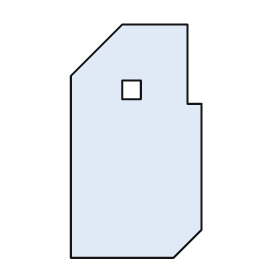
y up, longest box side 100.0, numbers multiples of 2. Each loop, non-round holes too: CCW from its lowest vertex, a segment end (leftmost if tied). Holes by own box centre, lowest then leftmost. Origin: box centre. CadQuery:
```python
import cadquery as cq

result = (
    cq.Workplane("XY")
    .moveTo(-28.0, -50.0)
    .lineTo(16.0, -50.0)
    .lineTo(28.0, -38.0)
    .lineTo(28.0, 16.0)
    .lineTo(22.0, 16.0)
    .lineTo(22.0, 50.0)
    .lineTo(-6.0, 50.0)
    .lineTo(-28.0, 28.0)
    .close()
    .moveTo(-6.0, 18.0)
    .lineTo(2.0, 18.0)
    .lineTo(2.0, 26.0)
    .lineTo(-6.0, 26.0)
    .close()
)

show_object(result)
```